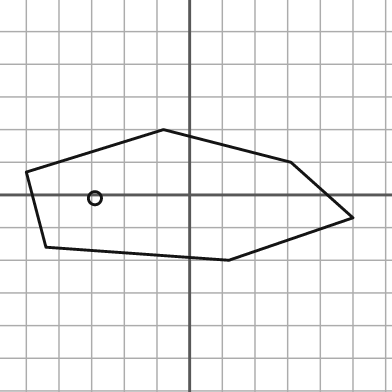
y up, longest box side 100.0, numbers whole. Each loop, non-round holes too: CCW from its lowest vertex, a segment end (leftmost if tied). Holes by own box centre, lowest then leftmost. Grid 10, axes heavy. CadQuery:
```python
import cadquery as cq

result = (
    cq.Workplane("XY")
    .moveTo(12.0, -20.0)
    .lineTo(50.0, -7.0)
    .lineTo(31.0, 10.0)
    .lineTo(-8.0, 20.0)
    .lineTo(-50.0, 7.0)
    .lineTo(-44.0, -16.0)
    .close()
    .moveTo(-29.0, -1.0)
    .circle(2.0)
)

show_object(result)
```